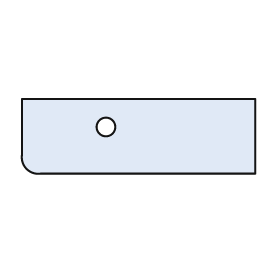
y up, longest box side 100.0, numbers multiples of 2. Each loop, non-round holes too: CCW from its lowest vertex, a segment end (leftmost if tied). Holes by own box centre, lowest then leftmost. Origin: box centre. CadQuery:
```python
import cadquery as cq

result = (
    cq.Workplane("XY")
    .moveTo(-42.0, -16.0)
    .lineTo(50.0, -16.0)
    .lineTo(50.0, 16.0)
    .lineTo(-50.0, 16.0)
    .lineTo(-50.0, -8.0)
    .threePointArc((-48.0, -14.0), (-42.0, -16.0))
    .close()
    .moveTo(-14.0, 4.0)
    .circle(4.0)
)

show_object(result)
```